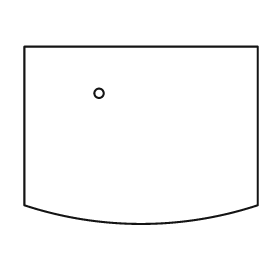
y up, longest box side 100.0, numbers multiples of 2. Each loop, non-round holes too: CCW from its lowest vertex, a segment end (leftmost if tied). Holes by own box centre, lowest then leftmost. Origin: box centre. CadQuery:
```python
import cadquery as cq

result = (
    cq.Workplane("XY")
    .moveTo(-50.0, -30.0)
    .threePointArc((0.0, -38.0), (50.0, -30.0))
    .lineTo(50.0, 38.0)
    .lineTo(-50.0, 38.0)
    .close()
    .moveTo(-18.0, 18.0)
    .circle(2.0)
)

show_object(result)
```